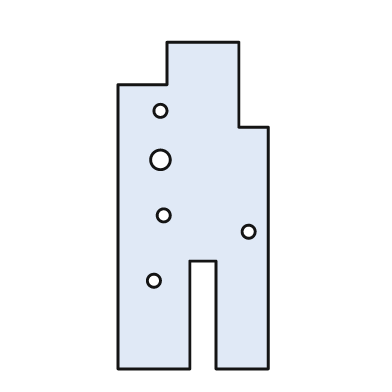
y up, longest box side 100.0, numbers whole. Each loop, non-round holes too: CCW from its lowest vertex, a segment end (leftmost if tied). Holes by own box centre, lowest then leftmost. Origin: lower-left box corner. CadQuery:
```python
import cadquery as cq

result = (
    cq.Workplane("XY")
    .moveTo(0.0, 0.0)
    .lineTo(22.0, 0.0)
    .lineTo(22.0, 33.0)
    .lineTo(30.0, 33.0)
    .lineTo(30.0, 0.0)
    .lineTo(46.0, 0.0)
    .lineTo(46.0, 74.0)
    .lineTo(37.0, 74.0)
    .lineTo(37.0, 100.0)
    .lineTo(15.0, 100.0)
    .lineTo(15.0, 87.0)
    .lineTo(0.0, 87.0)
    .close()
    .moveTo(11.0, 27.0)
    .circle(2.0)
    .moveTo(40.0, 42.0)
    .circle(2.0)
    .moveTo(14.0, 47.0)
    .circle(2.0)
    .moveTo(13.0, 64.0)
    .circle(3.0)
    .moveTo(13.0, 79.0)
    .circle(2.0)
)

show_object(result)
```